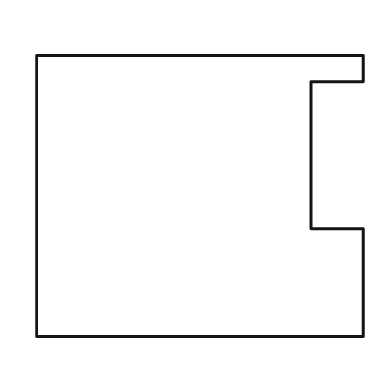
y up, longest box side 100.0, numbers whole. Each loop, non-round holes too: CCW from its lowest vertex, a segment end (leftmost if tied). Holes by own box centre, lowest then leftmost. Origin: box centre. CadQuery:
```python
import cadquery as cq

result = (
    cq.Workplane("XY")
    .moveTo(-50.0, -43.0)
    .lineTo(50.0, -43.0)
    .lineTo(50.0, -10.0)
    .lineTo(34.0, -10.0)
    .lineTo(34.0, 35.0)
    .lineTo(50.0, 35.0)
    .lineTo(50.0, 43.0)
    .lineTo(-50.0, 43.0)
    .close()
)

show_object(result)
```